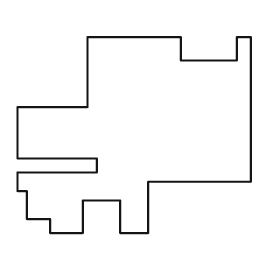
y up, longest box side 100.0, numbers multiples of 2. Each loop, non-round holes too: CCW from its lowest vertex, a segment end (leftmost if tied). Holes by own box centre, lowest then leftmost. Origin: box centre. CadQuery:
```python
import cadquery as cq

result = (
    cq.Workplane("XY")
    .moveTo(-36.0, -42.0)
    .lineTo(-22.0, -42.0)
    .lineTo(-22.0, -28.0)
    .lineTo(-6.0, -28.0)
    .lineTo(-6.0, -42.0)
    .lineTo(6.0, -42.0)
    .lineTo(6.0, -20.0)
    .lineTo(50.0, -20.0)
    .lineTo(50.0, 42.0)
    .lineTo(44.0, 42.0)
    .lineTo(44.0, 32.0)
    .lineTo(20.0, 32.0)
    .lineTo(20.0, 42.0)
    .lineTo(-20.0, 42.0)
    .lineTo(-20.0, 12.0)
    .lineTo(-50.0, 12.0)
    .lineTo(-50.0, -10.0)
    .lineTo(-16.0, -10.0)
    .lineTo(-16.0, -16.0)
    .lineTo(-50.0, -16.0)
    .lineTo(-50.0, -24.0)
    .lineTo(-46.0, -24.0)
    .lineTo(-46.0, -36.0)
    .lineTo(-36.0, -36.0)
    .close()
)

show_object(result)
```